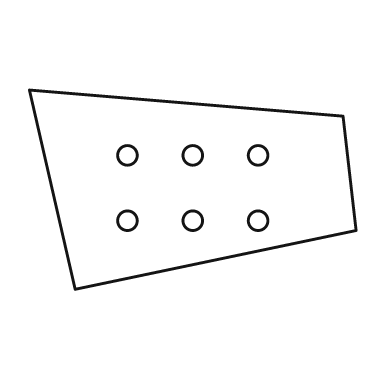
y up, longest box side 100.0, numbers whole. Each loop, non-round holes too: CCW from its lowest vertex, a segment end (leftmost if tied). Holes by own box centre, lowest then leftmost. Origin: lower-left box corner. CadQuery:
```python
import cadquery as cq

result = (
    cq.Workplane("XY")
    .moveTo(14.0, 0.0)
    .lineTo(100.0, 18.0)
    .lineTo(96.0, 53.0)
    .lineTo(0.0, 61.0)
    .close()
    .moveTo(30.0, 21.0)
    .circle(3.0)
    .moveTo(50.0, 21.0)
    .circle(3.0)
    .moveTo(70.0, 21.0)
    .circle(3.0)
    .moveTo(30.0, 41.0)
    .circle(3.0)
    .moveTo(50.0, 41.0)
    .circle(3.0)
    .moveTo(70.0, 41.0)
    .circle(3.0)
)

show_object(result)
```